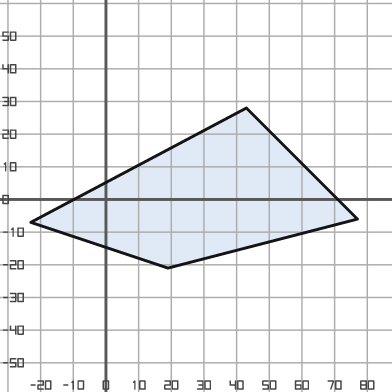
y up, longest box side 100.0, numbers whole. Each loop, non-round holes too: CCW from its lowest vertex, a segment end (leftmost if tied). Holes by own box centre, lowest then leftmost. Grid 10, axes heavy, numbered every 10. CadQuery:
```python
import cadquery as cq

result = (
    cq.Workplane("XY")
    .moveTo(19.0, -21.0)
    .lineTo(77.0, -6.0)
    .lineTo(43.0, 28.0)
    .lineTo(-23.0, -7.0)
    .close()
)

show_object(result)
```